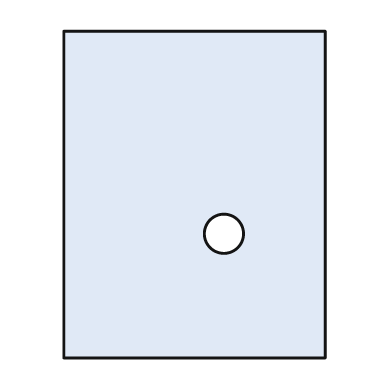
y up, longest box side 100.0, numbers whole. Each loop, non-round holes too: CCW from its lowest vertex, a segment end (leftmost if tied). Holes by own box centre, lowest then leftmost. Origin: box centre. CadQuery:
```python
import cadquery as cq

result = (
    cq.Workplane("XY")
    .moveTo(-40.0, -50.0)
    .lineTo(40.0, -50.0)
    .lineTo(40.0, 50.0)
    .lineTo(-40.0, 50.0)
    .close()
    .moveTo(9.0, -12.0)
    .circle(6.0)
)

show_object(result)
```